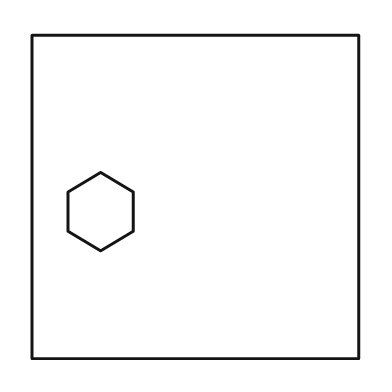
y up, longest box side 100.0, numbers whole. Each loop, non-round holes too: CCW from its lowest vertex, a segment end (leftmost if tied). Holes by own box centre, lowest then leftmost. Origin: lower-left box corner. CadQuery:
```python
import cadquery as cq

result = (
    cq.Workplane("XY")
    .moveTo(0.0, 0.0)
    .lineTo(100.0, 0.0)
    .lineTo(100.0, 99.0)
    .lineTo(0.0, 99.0)
    .close()
    .moveTo(21.0, 33.0)
    .lineTo(31.0, 39.0)
    .lineTo(31.0, 51.0)
    .lineTo(21.0, 57.0)
    .lineTo(11.0, 51.0)
    .lineTo(11.0, 39.0)
    .close()
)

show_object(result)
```